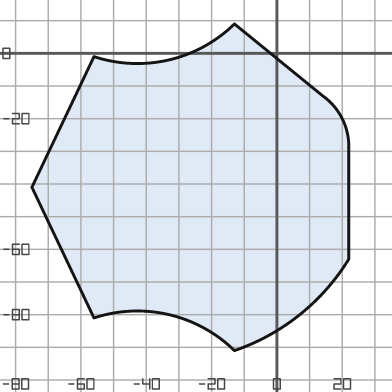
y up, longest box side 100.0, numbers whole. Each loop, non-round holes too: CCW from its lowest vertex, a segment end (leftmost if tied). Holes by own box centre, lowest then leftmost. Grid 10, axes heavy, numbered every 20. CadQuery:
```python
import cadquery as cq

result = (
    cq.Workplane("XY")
    .moveTo(-13.0, -91.0)
    .threePointArc((7.0, -80.0), (22.0, -63.0))
    .lineTo(22.0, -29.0)
    .threePointArc((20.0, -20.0), (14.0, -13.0))
    .lineTo(-13.0, 9.0)
    .threePointArc((-33.0, -2.0), (-56.0, -1.0))
    .lineTo(-75.0, -41.0)
    .lineTo(-56.0, -81.0)
    .threePointArc((-33.0, -80.0), (-13.0, -91.0))
    .close()
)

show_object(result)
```